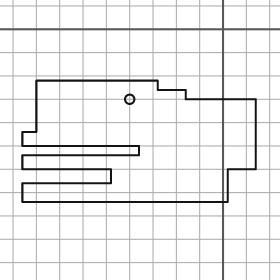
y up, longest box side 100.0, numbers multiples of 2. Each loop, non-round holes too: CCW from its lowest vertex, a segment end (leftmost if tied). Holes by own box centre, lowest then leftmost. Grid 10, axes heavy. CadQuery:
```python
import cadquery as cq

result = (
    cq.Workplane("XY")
    .moveTo(-86.0, -74.0)
    .lineTo(2.0, -74.0)
    .lineTo(2.0, -60.0)
    .lineTo(14.0, -60.0)
    .lineTo(14.0, -30.0)
    .lineTo(-16.0, -30.0)
    .lineTo(-16.0, -26.0)
    .lineTo(-28.0, -26.0)
    .lineTo(-28.0, -22.0)
    .lineTo(-80.0, -22.0)
    .lineTo(-80.0, -44.0)
    .lineTo(-86.0, -44.0)
    .lineTo(-86.0, -50.0)
    .lineTo(-36.0, -50.0)
    .lineTo(-36.0, -54.0)
    .lineTo(-86.0, -54.0)
    .lineTo(-86.0, -60.0)
    .lineTo(-48.0, -60.0)
    .lineTo(-48.0, -66.0)
    .lineTo(-86.0, -66.0)
    .close()
    .moveTo(-40.0, -30.0)
    .circle(2.0)
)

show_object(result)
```